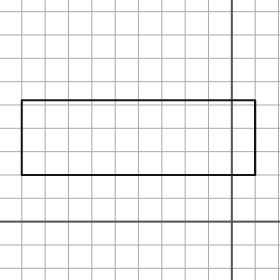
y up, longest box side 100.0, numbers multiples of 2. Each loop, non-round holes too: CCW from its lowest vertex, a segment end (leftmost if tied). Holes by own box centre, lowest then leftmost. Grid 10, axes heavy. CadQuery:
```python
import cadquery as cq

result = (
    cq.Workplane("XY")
    .moveTo(-90.0, 20.0)
    .lineTo(10.0, 20.0)
    .lineTo(10.0, 52.0)
    .lineTo(-90.0, 52.0)
    .close()
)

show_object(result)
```